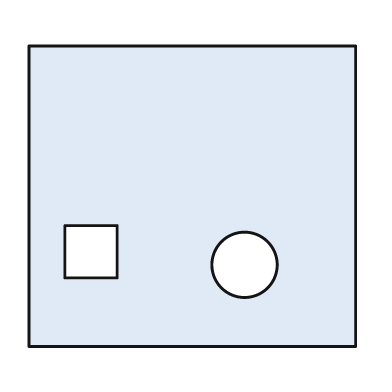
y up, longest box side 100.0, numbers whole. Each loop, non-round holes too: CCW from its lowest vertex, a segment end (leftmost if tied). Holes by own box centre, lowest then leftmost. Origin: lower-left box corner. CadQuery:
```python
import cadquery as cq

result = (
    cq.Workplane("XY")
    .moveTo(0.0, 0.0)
    .lineTo(100.0, 0.0)
    .lineTo(100.0, 92.0)
    .lineTo(0.0, 92.0)
    .close()
    .moveTo(66.0, 25.0)
    .circle(10.0)
    .moveTo(11.0, 21.0)
    .lineTo(27.0, 21.0)
    .lineTo(27.0, 37.0)
    .lineTo(11.0, 37.0)
    .close()
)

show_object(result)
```